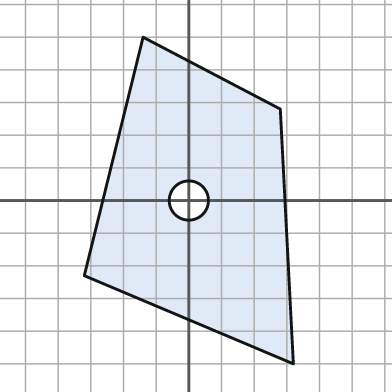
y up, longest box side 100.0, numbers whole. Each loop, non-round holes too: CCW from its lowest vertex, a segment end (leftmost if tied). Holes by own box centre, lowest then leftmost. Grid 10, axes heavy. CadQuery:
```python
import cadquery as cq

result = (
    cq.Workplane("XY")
    .moveTo(32.0, -50.0)
    .lineTo(28.0, 28.0)
    .lineTo(-14.0, 50.0)
    .lineTo(-32.0, -23.0)
    .close()
    .moveTo(0.0, 0.0)
    .circle(6.0)
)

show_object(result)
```